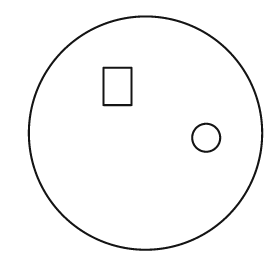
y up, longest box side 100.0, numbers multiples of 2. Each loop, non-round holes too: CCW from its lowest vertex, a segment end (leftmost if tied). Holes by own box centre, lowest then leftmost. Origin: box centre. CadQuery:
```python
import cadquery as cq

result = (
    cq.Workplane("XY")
    .moveTo(0.0, 0.0)
    .circle(50.0)
    .moveTo(26.0, -2.0)
    .circle(6.0)
    .moveTo(-18.0, 12.0)
    .lineTo(-6.0, 12.0)
    .lineTo(-6.0, 28.0)
    .lineTo(-18.0, 28.0)
    .close()
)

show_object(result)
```